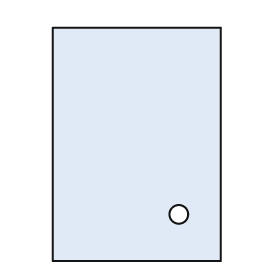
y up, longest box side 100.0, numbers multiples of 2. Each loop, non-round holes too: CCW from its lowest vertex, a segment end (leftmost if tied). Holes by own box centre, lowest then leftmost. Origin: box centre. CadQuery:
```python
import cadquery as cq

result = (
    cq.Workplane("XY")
    .moveTo(-36.0, -50.0)
    .lineTo(36.0, -50.0)
    .lineTo(36.0, 50.0)
    .lineTo(-36.0, 50.0)
    .close()
    .moveTo(18.0, -30.0)
    .circle(4.0)
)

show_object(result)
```